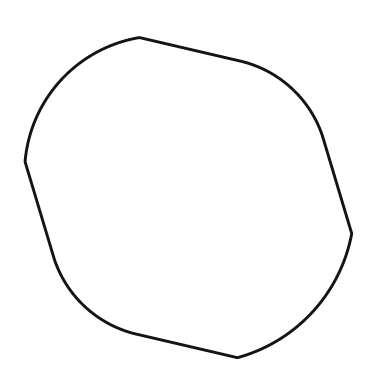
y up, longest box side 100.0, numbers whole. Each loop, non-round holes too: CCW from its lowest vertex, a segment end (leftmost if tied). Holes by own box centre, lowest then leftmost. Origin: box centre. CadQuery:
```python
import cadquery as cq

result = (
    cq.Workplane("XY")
    .moveTo(15.0, -49.0)
    .threePointArc((38.0, -35.0), (50.0, -11.0))
    .lineTo(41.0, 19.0)
    .threePointArc((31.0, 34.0), (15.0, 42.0))
    .lineTo(-15.0, 49.0)
    .threePointArc((-39.0, 36.0), (-50.0, 11.0))
    .lineTo(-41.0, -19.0)
    .threePointArc((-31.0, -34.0), (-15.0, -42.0))
    .close()
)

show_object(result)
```